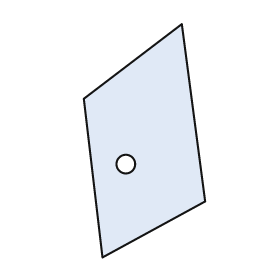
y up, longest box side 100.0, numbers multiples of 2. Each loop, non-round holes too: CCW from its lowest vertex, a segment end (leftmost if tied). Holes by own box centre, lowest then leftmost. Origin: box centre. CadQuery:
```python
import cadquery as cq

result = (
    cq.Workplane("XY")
    .moveTo(-18.0, -50.0)
    .lineTo(26.0, -26.0)
    .lineTo(16.0, 50.0)
    .lineTo(-26.0, 18.0)
    .close()
    .moveTo(-8.0, -10.0)
    .circle(4.0)
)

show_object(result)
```